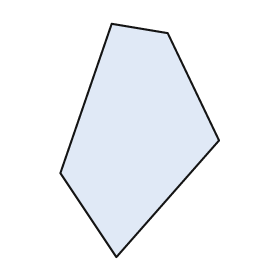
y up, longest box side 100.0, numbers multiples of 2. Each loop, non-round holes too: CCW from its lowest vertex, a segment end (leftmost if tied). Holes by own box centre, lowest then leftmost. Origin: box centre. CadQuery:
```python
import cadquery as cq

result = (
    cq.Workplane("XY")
    .moveTo(-10.0, -50.0)
    .lineTo(34.0, 0.0)
    .lineTo(12.0, 46.0)
    .lineTo(-12.0, 50.0)
    .lineTo(-34.0, -14.0)
    .close()
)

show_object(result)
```